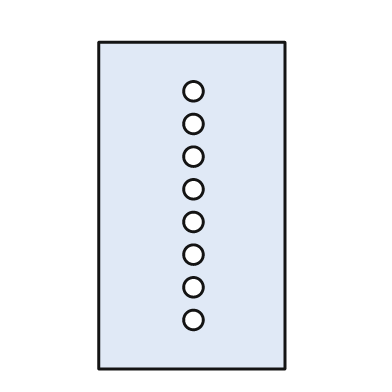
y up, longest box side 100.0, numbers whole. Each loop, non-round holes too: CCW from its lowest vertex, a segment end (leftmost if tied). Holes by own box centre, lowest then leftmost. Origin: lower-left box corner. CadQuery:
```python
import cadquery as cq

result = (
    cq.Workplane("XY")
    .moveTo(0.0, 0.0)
    .lineTo(57.0, 0.0)
    .lineTo(57.0, 100.0)
    .lineTo(0.0, 100.0)
    .close()
    .moveTo(29.0, 15.0)
    .circle(3.0)
    .moveTo(29.0, 25.0)
    .circle(3.0)
    .moveTo(29.0, 35.0)
    .circle(3.0)
    .moveTo(29.0, 45.0)
    .circle(3.0)
    .moveTo(29.0, 55.0)
    .circle(3.0)
    .moveTo(29.0, 65.0)
    .circle(3.0)
    .moveTo(29.0, 75.0)
    .circle(3.0)
    .moveTo(29.0, 85.0)
    .circle(3.0)
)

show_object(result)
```